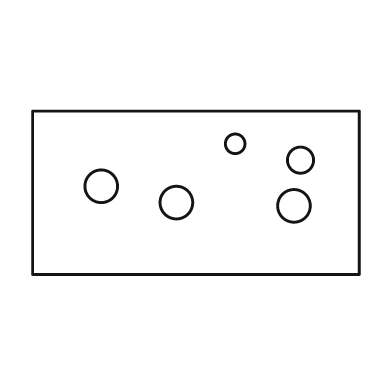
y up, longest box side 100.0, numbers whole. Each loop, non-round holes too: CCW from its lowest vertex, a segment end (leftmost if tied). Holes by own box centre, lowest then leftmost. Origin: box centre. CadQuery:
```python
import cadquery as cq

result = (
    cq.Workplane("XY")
    .moveTo(-50.0, -25.0)
    .lineTo(50.0, -25.0)
    .lineTo(50.0, 25.0)
    .lineTo(-50.0, 25.0)
    .close()
    .moveTo(30.0, -4.0)
    .circle(5.0)
    .moveTo(-6.0, -3.0)
    .circle(5.0)
    .moveTo(-29.0, 2.0)
    .circle(5.0)
    .moveTo(32.0, 10.0)
    .circle(4.0)
    .moveTo(12.0, 15.0)
    .circle(3.0)
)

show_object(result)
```